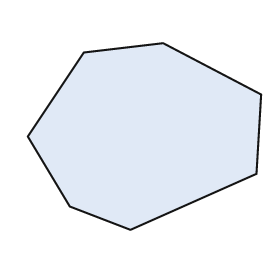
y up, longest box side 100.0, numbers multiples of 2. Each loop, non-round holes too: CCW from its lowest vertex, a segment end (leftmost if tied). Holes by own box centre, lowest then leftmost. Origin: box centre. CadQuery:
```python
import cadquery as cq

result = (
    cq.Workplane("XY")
    .moveTo(-6.0, -40.0)
    .lineTo(48.0, -16.0)
    .lineTo(50.0, 18.0)
    .lineTo(8.0, 40.0)
    .lineTo(-26.0, 36.0)
    .lineTo(-50.0, 0.0)
    .lineTo(-32.0, -30.0)
    .close()
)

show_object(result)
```